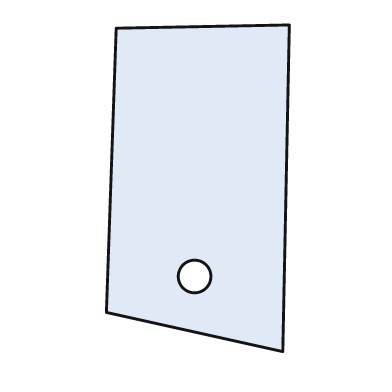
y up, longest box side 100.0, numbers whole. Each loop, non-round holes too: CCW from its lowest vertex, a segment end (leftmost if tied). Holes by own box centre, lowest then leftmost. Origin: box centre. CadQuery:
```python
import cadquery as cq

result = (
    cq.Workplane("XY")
    .moveTo(26.0, -50.0)
    .lineTo(28.0, 50.0)
    .lineTo(-25.0, 49.0)
    .lineTo(-28.0, -38.0)
    .close()
    .moveTo(-1.0, -27.0)
    .circle(5.0)
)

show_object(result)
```